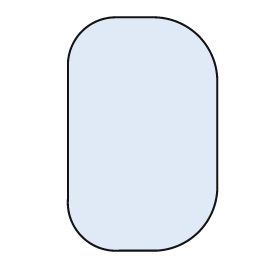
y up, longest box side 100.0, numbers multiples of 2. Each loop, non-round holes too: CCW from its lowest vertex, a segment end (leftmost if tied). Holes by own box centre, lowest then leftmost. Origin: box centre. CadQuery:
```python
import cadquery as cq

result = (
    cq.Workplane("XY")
    .moveTo(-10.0, -50.0)
    .lineTo(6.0, -50.0)
    .threePointArc((24.0, -42.0), (32.0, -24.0))
    .lineTo(32.0, 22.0)
    .threePointArc((24.0, 42.0), (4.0, 50.0))
    .lineTo(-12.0, 50.0)
    .threePointArc((-26.0, 44.0), (-32.0, 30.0))
    .lineTo(-32.0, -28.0)
    .threePointArc((-26.0, -44.0), (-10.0, -50.0))
    .close()
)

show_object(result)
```